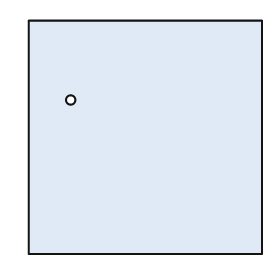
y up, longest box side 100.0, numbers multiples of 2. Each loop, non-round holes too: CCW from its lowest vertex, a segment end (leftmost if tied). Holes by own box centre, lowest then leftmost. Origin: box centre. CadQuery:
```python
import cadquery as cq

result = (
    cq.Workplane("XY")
    .moveTo(-50.0, -50.0)
    .lineTo(50.0, -50.0)
    .lineTo(50.0, 50.0)
    .lineTo(-50.0, 50.0)
    .close()
    .moveTo(-32.0, 16.0)
    .circle(2.0)
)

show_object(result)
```